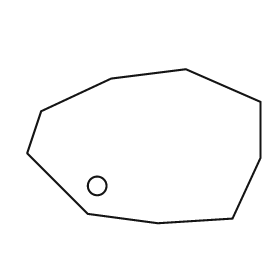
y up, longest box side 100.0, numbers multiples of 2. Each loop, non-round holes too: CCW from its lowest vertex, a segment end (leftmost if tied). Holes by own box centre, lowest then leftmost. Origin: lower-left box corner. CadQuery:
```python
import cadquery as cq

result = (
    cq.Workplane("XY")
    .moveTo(56.0, 0.0)
    .lineTo(88.0, 2.0)
    .lineTo(100.0, 28.0)
    .lineTo(100.0, 52.0)
    .lineTo(68.0, 66.0)
    .lineTo(36.0, 62.0)
    .lineTo(6.0, 48.0)
    .lineTo(0.0, 30.0)
    .lineTo(26.0, 4.0)
    .close()
    .moveTo(30.0, 16.0)
    .circle(4.0)
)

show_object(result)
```